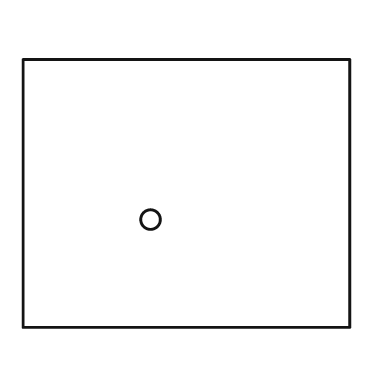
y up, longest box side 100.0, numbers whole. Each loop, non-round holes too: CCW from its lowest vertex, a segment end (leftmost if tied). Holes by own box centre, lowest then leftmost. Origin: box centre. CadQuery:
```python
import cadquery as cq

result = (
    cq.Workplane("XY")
    .moveTo(-50.0, -41.0)
    .lineTo(50.0, -41.0)
    .lineTo(50.0, 41.0)
    .lineTo(-50.0, 41.0)
    .close()
    .moveTo(-11.0, -8.0)
    .circle(3.0)
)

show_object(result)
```